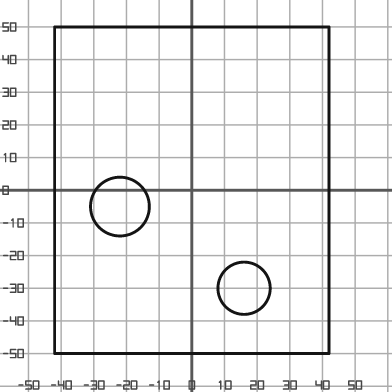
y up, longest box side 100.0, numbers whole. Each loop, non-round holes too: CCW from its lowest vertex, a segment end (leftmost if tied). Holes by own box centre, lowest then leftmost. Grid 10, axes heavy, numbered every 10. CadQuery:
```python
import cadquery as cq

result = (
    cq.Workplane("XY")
    .moveTo(-42.0, -50.0)
    .lineTo(42.0, -50.0)
    .lineTo(42.0, 50.0)
    .lineTo(-42.0, 50.0)
    .close()
    .moveTo(16.0, -30.0)
    .circle(8.0)
    .moveTo(-22.0, -5.0)
    .circle(9.0)
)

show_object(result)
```